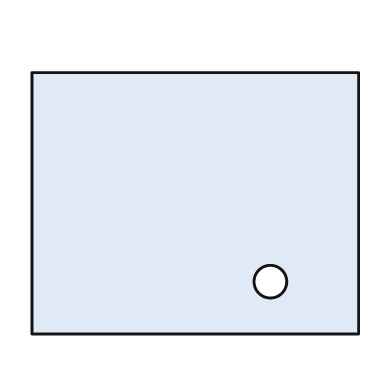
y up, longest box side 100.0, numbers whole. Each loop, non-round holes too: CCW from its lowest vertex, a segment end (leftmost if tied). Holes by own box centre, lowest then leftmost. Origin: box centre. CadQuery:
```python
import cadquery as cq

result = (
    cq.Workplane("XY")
    .moveTo(-50.0, -40.0)
    .lineTo(50.0, -40.0)
    .lineTo(50.0, 40.0)
    .lineTo(-50.0, 40.0)
    .close()
    .moveTo(23.0, -24.0)
    .circle(5.0)
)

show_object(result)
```